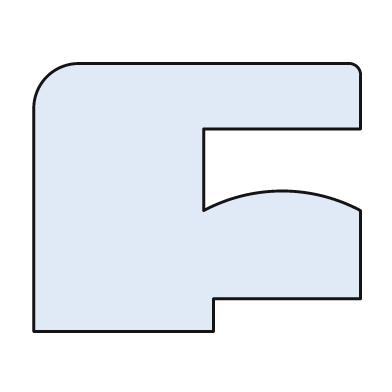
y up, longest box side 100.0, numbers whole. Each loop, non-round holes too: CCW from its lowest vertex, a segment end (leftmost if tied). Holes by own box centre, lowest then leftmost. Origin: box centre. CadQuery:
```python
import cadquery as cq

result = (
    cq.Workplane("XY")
    .moveTo(-50.0, -41.0)
    .lineTo(5.0, -41.0)
    .lineTo(5.0, -31.0)
    .lineTo(50.0, -31.0)
    .lineTo(50.0, -4.0)
    .threePointArc((26.0, 2.0), (2.0, -4.0))
    .lineTo(2.0, 21.0)
    .lineTo(50.0, 21.0)
    .lineTo(50.0, 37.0)
    .threePointArc((49.0, 40.0), (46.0, 41.0))
    .lineTo(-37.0, 41.0)
    .threePointArc((-46.0, 37.0), (-50.0, 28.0))
    .close()
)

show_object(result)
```